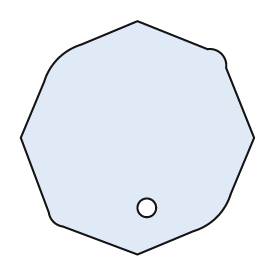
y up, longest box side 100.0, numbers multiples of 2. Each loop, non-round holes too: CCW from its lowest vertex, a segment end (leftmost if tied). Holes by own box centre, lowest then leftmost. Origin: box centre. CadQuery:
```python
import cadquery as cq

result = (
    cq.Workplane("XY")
    .moveTo(0.0, -50.0)
    .lineTo(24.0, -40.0)
    .threePointArc((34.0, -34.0), (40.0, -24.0))
    .lineTo(50.0, 0.0)
    .lineTo(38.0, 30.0)
    .threePointArc((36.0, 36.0), (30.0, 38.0))
    .lineTo(0.0, 50.0)
    .lineTo(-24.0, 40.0)
    .threePointArc((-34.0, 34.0), (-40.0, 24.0))
    .lineTo(-50.0, 0.0)
    .lineTo(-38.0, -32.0)
    .threePointArc((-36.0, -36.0), (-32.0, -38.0))
    .close()
    .moveTo(4.0, -30.0)
    .circle(4.0)
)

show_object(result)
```